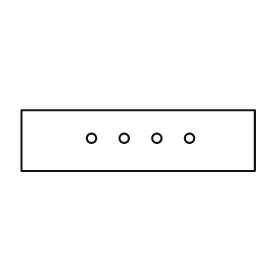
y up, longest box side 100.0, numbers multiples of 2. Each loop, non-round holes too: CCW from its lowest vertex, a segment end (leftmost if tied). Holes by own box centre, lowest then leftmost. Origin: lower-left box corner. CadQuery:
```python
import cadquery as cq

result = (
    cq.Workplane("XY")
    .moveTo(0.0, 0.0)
    .lineTo(100.0, 0.0)
    .lineTo(100.0, 26.0)
    .lineTo(0.0, 26.0)
    .close()
    .moveTo(30.0, 14.0)
    .circle(2.0)
    .moveTo(44.0, 14.0)
    .circle(2.0)
    .moveTo(58.0, 14.0)
    .circle(2.0)
    .moveTo(72.0, 14.0)
    .circle(2.0)
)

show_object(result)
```